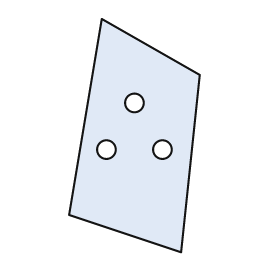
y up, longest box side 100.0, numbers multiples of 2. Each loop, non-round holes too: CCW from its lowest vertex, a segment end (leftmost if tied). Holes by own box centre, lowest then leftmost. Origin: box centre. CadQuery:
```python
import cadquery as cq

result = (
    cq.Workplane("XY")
    .moveTo(20.0, -50.0)
    .lineTo(28.0, 26.0)
    .lineTo(-14.0, 50.0)
    .lineTo(-28.0, -34.0)
    .close()
    .moveTo(-12.0, -6.0)
    .circle(4.0)
    .moveTo(12.0, -6.0)
    .circle(4.0)
    .moveTo(0.0, 14.0)
    .circle(4.0)
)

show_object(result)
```